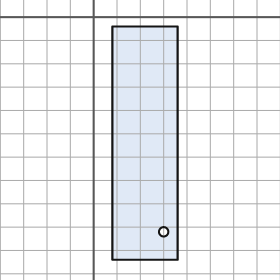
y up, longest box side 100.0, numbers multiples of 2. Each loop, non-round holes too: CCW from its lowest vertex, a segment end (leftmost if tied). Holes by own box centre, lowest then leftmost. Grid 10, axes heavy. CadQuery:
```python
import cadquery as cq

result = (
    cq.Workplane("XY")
    .moveTo(8.0, -104.0)
    .lineTo(36.0, -104.0)
    .lineTo(36.0, -4.0)
    .lineTo(8.0, -4.0)
    .close()
    .moveTo(30.0, -92.0)
    .circle(2.0)
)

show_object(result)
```